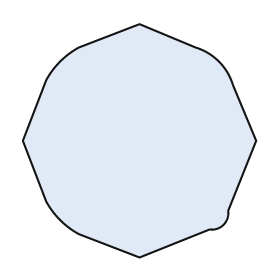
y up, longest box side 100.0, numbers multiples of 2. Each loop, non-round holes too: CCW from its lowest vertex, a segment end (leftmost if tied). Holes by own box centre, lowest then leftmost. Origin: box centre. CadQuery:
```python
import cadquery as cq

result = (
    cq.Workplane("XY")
    .moveTo(0.0, -50.0)
    .lineTo(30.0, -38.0)
    .threePointArc((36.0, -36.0), (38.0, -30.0))
    .lineTo(50.0, 0.0)
    .lineTo(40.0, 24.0)
    .threePointArc((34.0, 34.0), (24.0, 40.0))
    .lineTo(0.0, 50.0)
    .lineTo(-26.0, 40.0)
    .threePointArc((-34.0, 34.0), (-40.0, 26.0))
    .lineTo(-50.0, 0.0)
    .lineTo(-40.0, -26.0)
    .threePointArc((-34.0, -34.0), (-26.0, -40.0))
    .close()
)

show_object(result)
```